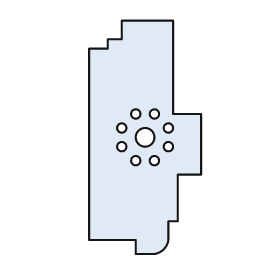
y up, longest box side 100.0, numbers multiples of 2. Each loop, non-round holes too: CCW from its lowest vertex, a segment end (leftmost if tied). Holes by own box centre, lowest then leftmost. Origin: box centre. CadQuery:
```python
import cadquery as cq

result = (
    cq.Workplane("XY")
    .moveTo(-4.0, -50.0)
    .lineTo(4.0, -50.0)
    .threePointArc((8.0, -48.0), (10.0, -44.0))
    .lineTo(10.0, -36.0)
    .lineTo(14.0, -36.0)
    .lineTo(14.0, -16.0)
    .lineTo(24.0, -16.0)
    .lineTo(24.0, 10.0)
    .lineTo(12.0, 10.0)
    .lineTo(12.0, 50.0)
    .lineTo(-10.0, 50.0)
    .lineTo(-10.0, 42.0)
    .lineTo(-16.0, 42.0)
    .lineTo(-16.0, 38.0)
    .lineTo(-24.0, 38.0)
    .lineTo(-24.0, -44.0)
    .lineTo(-4.0, -44.0)
    .close()
    .moveTo(-4.0, -10.0)
    .circle(2.0)
    .moveTo(4.0, -10.0)
    .circle(2.0)
    .moveTo(-10.0, -4.0)
    .circle(2.0)
    .moveTo(10.0, -4.0)
    .circle(2.0)
    .moveTo(0.0, 0.0)
    .circle(4.0)
    .moveTo(-10.0, 4.0)
    .circle(2.0)
    .moveTo(10.0, 4.0)
    .circle(2.0)
    .moveTo(-4.0, 10.0)
    .circle(2.0)
    .moveTo(4.0, 10.0)
    .circle(2.0)
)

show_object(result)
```